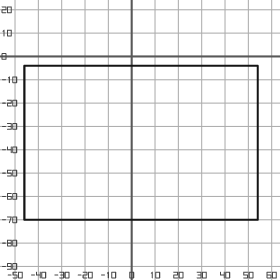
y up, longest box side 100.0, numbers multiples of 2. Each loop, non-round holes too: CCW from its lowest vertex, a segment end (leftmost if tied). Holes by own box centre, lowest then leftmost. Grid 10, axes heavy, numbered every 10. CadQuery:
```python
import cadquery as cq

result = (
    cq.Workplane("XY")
    .moveTo(-46.0, -70.0)
    .lineTo(54.0, -70.0)
    .lineTo(54.0, -4.0)
    .lineTo(-46.0, -4.0)
    .close()
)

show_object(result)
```